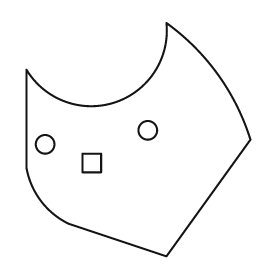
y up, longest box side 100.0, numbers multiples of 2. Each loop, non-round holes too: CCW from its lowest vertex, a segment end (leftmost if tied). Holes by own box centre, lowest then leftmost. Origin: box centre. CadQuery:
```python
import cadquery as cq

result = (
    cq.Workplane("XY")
    .moveTo(12.0, -50.0)
    .lineTo(48.0, 0.0)
    .threePointArc((34.0, 28.0), (12.0, 50.0))
    .threePointArc((-10.0, 16.0), (-48.0, 30.0))
    .lineTo(-48.0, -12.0)
    .threePointArc((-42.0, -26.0), (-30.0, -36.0))
    .close()
    .moveTo(-24.0, -14.0)
    .lineTo(-16.0, -14.0)
    .lineTo(-16.0, -6.0)
    .lineTo(-24.0, -6.0)
    .close()
    .moveTo(-40.0, -2.0)
    .circle(4.0)
    .moveTo(4.0, 4.0)
    .circle(4.0)
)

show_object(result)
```